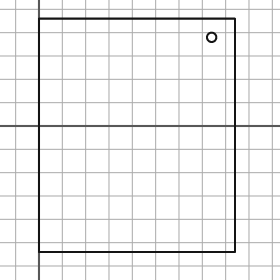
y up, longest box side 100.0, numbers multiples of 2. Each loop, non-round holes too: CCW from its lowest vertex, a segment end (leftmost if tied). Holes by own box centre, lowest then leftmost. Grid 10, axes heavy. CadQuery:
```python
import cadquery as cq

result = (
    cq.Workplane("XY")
    .moveTo(0.0, -54.0)
    .lineTo(84.0, -54.0)
    .lineTo(84.0, 46.0)
    .lineTo(0.0, 46.0)
    .close()
    .moveTo(74.0, 38.0)
    .circle(2.0)
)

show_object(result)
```